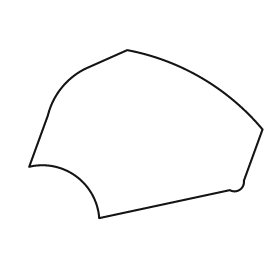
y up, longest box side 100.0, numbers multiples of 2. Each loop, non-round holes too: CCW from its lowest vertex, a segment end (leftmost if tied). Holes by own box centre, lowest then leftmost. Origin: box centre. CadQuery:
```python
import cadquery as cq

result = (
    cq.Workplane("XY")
    .moveTo(-20.0, -36.0)
    .lineTo(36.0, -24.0)
    .threePointArc((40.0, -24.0), (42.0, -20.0))
    .lineTo(50.0, 2.0)
    .threePointArc((24.0, 24.0), (-8.0, 36.0))
    .lineTo(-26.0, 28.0)
    .threePointArc((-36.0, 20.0), (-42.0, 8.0))
    .lineTo(-50.0, -14.0)
    .threePointArc((-30.0, -18.0), (-20.0, -36.0))
    .close()
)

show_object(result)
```